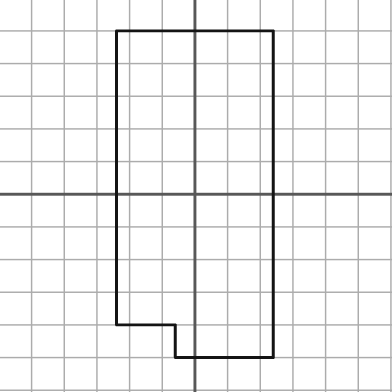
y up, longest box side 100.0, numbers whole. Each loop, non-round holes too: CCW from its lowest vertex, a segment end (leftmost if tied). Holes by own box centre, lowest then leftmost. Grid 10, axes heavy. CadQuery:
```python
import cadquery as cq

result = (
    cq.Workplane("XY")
    .moveTo(-6.0, -50.0)
    .lineTo(24.0, -50.0)
    .lineTo(24.0, 50.0)
    .lineTo(-24.0, 50.0)
    .lineTo(-24.0, -40.0)
    .lineTo(-6.0, -40.0)
    .close()
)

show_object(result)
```